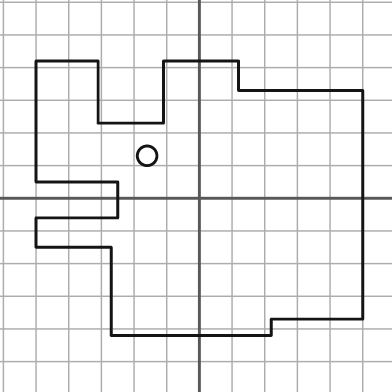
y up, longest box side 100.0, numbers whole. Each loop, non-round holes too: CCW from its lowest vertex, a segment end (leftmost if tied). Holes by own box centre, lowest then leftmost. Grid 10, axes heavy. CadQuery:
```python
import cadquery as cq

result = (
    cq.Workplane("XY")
    .moveTo(-27.0, -42.0)
    .lineTo(22.0, -42.0)
    .lineTo(22.0, -37.0)
    .lineTo(50.0, -37.0)
    .lineTo(50.0, 33.0)
    .lineTo(12.0, 33.0)
    .lineTo(12.0, 42.0)
    .lineTo(-11.0, 42.0)
    .lineTo(-11.0, 23.0)
    .lineTo(-31.0, 23.0)
    .lineTo(-31.0, 42.0)
    .lineTo(-50.0, 42.0)
    .lineTo(-50.0, 5.0)
    .lineTo(-25.0, 5.0)
    .lineTo(-25.0, -6.0)
    .lineTo(-50.0, -6.0)
    .lineTo(-50.0, -15.0)
    .lineTo(-27.0, -15.0)
    .close()
    .moveTo(-16.0, 13.0)
    .circle(3.0)
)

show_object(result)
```